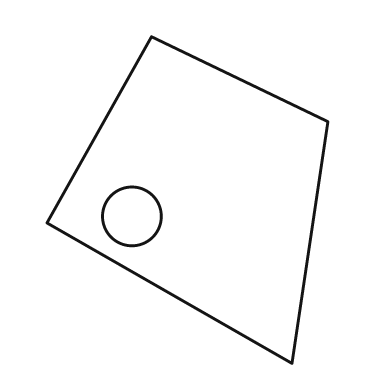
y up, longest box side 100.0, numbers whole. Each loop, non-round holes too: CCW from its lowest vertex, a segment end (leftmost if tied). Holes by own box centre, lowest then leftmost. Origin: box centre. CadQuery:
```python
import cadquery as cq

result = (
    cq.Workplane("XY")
    .moveTo(32.0, -50.0)
    .lineTo(43.0, 24.0)
    .lineTo(-11.0, 50.0)
    .lineTo(-43.0, -7.0)
    .close()
    .moveTo(-17.0, -5.0)
    .circle(9.0)
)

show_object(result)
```